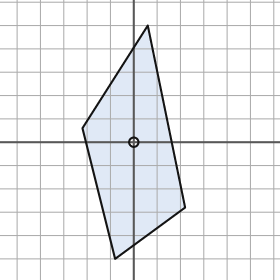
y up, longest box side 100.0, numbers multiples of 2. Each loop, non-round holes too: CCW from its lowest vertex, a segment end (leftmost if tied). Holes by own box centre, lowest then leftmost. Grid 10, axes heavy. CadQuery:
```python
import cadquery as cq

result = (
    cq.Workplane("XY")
    .moveTo(-8.0, -50.0)
    .lineTo(22.0, -28.0)
    .lineTo(6.0, 50.0)
    .lineTo(-22.0, 6.0)
    .close()
    .moveTo(0.0, 0.0)
    .circle(2.0)
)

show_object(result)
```